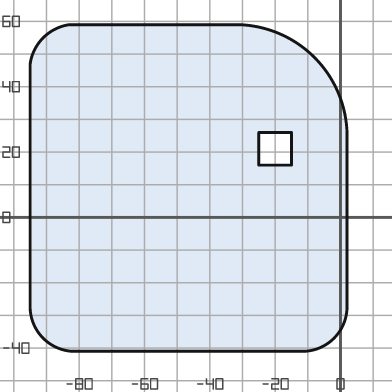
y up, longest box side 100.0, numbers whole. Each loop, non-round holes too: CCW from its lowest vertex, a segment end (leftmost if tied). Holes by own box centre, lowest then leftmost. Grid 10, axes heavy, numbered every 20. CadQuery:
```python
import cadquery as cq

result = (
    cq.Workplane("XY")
    .moveTo(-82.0, -41.0)
    .lineTo(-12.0, -41.0)
    .threePointArc((-2.0, -37.0), (2.0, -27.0))
    .lineTo(2.0, 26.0)
    .threePointArc((-8.0, 49.0), (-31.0, 59.0))
    .lineTo(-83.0, 59.0)
    .threePointArc((-91.0, 55.0), (-95.0, 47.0))
    .lineTo(-95.0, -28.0)
    .threePointArc((-91.0, -37.0), (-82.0, -41.0))
    .close()
    .moveTo(-25.0, 16.0)
    .lineTo(-15.0, 16.0)
    .lineTo(-15.0, 26.0)
    .lineTo(-25.0, 26.0)
    .close()
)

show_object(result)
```